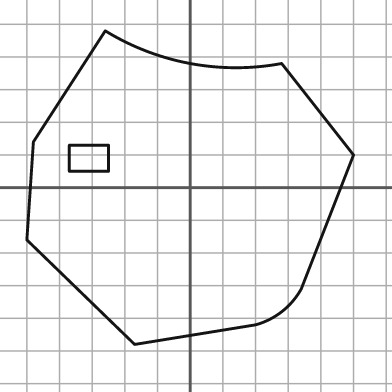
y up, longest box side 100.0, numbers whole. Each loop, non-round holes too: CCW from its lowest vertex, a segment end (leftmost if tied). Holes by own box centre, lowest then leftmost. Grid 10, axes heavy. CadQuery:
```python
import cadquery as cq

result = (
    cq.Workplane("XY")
    .moveTo(-17.0, -48.0)
    .lineTo(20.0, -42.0)
    .threePointArc((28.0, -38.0), (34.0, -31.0))
    .lineTo(50.0, 10.0)
    .lineTo(28.0, 38.0)
    .threePointArc((0.0, 38.0), (-26.0, 48.0))
    .lineTo(-48.0, 14.0)
    .lineTo(-50.0, -16.0)
    .close()
    .moveTo(-37.0, 5.0)
    .lineTo(-25.0, 5.0)
    .lineTo(-25.0, 13.0)
    .lineTo(-37.0, 13.0)
    .close()
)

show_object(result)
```